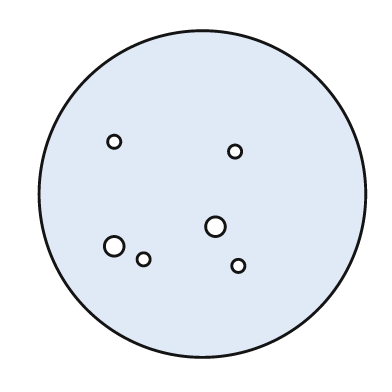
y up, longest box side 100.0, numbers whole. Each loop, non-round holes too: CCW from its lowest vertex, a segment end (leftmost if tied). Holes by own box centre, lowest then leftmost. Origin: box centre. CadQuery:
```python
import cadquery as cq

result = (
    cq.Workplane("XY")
    .moveTo(0.0, 0.0)
    .circle(50.0)
    .moveTo(11.0, -22.0)
    .circle(2.0)
    .moveTo(-18.0, -20.0)
    .circle(2.0)
    .moveTo(-27.0, -16.0)
    .circle(3.0)
    .moveTo(4.0, -10.0)
    .circle(3.0)
    .moveTo(10.0, 13.0)
    .circle(2.0)
    .moveTo(-27.0, 16.0)
    .circle(2.0)
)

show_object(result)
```